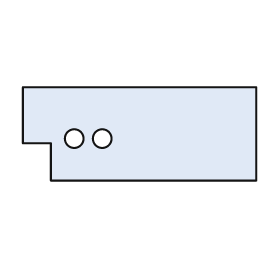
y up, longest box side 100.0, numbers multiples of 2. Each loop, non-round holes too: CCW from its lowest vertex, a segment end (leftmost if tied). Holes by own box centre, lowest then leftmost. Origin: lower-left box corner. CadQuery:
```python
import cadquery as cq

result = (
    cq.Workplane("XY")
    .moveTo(12.0, 0.0)
    .lineTo(100.0, 0.0)
    .lineTo(100.0, 40.0)
    .lineTo(0.0, 40.0)
    .lineTo(0.0, 16.0)
    .lineTo(12.0, 16.0)
    .close()
    .moveTo(22.0, 18.0)
    .circle(4.0)
    .moveTo(34.0, 18.0)
    .circle(4.0)
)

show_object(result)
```